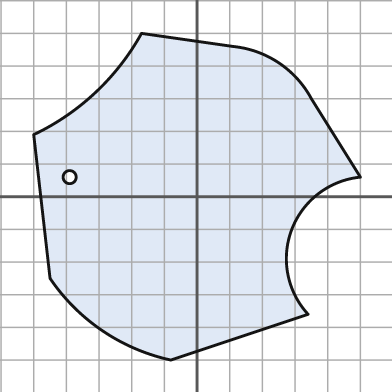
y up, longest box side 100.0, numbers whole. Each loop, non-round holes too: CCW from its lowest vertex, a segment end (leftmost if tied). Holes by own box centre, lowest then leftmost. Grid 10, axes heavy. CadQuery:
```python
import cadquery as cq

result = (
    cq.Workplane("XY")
    .moveTo(-8.0, -50.0)
    .lineTo(34.0, -36.0)
    .threePointArc((29.0, -10.0), (50.0, 6.0))
    .lineTo(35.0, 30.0)
    .threePointArc((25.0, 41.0), (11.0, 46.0))
    .lineTo(-17.0, 50.0)
    .threePointArc((-31.0, 32.0), (-50.0, 19.0))
    .lineTo(-45.0, -25.0)
    .threePointArc((-29.0, -41.0), (-8.0, -50.0))
    .close()
    .moveTo(-39.0, 6.0)
    .circle(2.0)
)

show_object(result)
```